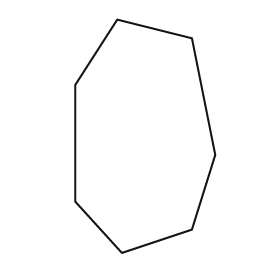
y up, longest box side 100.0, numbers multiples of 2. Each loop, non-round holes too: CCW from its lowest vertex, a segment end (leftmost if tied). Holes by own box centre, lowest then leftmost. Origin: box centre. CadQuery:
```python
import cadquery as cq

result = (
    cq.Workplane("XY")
    .moveTo(-10.0, -50.0)
    .lineTo(20.0, -40.0)
    .lineTo(30.0, -8.0)
    .lineTo(20.0, 42.0)
    .lineTo(-12.0, 50.0)
    .lineTo(-30.0, 22.0)
    .lineTo(-30.0, -28.0)
    .close()
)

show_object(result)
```